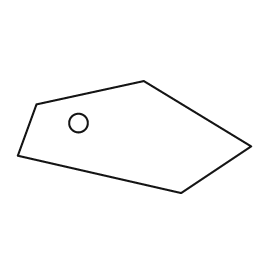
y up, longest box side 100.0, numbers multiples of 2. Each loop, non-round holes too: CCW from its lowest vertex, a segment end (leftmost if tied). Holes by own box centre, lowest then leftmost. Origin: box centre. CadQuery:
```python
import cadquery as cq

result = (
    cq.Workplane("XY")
    .moveTo(20.0, -24.0)
    .lineTo(50.0, -4.0)
    .lineTo(4.0, 24.0)
    .lineTo(-42.0, 14.0)
    .lineTo(-50.0, -8.0)
    .close()
    .moveTo(-24.0, 6.0)
    .circle(4.0)
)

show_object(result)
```